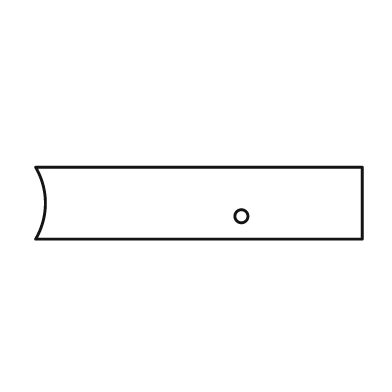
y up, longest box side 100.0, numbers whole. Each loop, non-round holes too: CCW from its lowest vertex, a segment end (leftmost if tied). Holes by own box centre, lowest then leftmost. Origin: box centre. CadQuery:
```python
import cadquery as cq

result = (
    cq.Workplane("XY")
    .moveTo(-50.0, -11.0)
    .lineTo(50.0, -11.0)
    .lineTo(50.0, 11.0)
    .lineTo(-50.0, 11.0)
    .threePointArc((-47.0, 0.0), (-50.0, -11.0))
    .close()
    .moveTo(13.0, -4.0)
    .circle(2.0)
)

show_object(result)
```